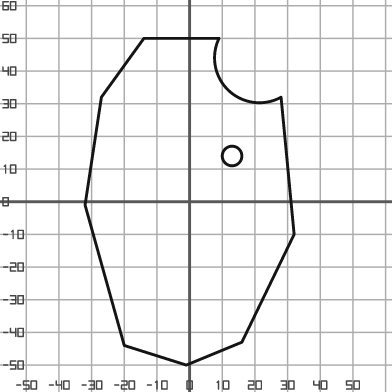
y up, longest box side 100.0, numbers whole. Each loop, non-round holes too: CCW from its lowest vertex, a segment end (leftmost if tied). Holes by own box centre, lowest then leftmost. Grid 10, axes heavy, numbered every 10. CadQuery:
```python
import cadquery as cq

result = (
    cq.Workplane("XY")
    .moveTo(-1.0, -50.0)
    .lineTo(16.0, -43.0)
    .lineTo(32.0, -10.0)
    .lineTo(28.0, 32.0)
    .threePointArc((12.0, 34.0), (9.0, 50.0))
    .lineTo(-14.0, 50.0)
    .lineTo(-27.0, 32.0)
    .lineTo(-32.0, -1.0)
    .lineTo(-20.0, -44.0)
    .close()
    .moveTo(13.0, 14.0)
    .circle(3.0)
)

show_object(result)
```